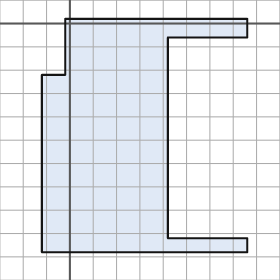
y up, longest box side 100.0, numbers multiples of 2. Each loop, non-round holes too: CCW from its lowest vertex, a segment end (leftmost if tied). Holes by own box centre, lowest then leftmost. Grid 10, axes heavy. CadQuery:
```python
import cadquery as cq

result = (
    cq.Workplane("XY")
    .moveTo(-12.0, -98.0)
    .lineTo(76.0, -98.0)
    .lineTo(76.0, -92.0)
    .lineTo(42.0, -92.0)
    .lineTo(42.0, -6.0)
    .lineTo(76.0, -6.0)
    .lineTo(76.0, 2.0)
    .lineTo(-2.0, 2.0)
    .lineTo(-2.0, -22.0)
    .lineTo(-12.0, -22.0)
    .close()
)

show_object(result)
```